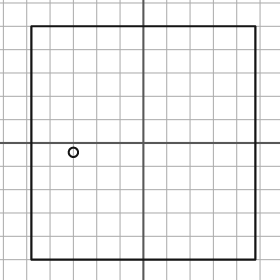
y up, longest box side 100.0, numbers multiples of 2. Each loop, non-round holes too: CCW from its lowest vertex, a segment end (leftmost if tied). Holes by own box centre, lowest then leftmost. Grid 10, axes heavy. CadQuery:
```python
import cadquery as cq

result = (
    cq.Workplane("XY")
    .moveTo(-48.0, -50.0)
    .lineTo(48.0, -50.0)
    .lineTo(48.0, 50.0)
    .lineTo(-48.0, 50.0)
    .close()
    .moveTo(-30.0, -4.0)
    .circle(2.0)
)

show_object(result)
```